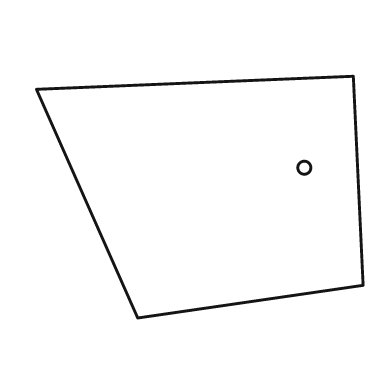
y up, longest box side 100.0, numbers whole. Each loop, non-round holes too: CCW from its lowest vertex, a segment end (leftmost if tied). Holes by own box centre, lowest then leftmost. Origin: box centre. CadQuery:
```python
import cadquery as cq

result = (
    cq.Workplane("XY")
    .moveTo(-19.0, -37.0)
    .lineTo(50.0, -27.0)
    .lineTo(47.0, 37.0)
    .lineTo(-50.0, 33.0)
    .close()
    .moveTo(32.0, 9.0)
    .circle(2.0)
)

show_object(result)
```